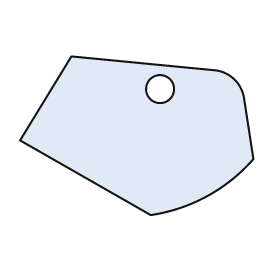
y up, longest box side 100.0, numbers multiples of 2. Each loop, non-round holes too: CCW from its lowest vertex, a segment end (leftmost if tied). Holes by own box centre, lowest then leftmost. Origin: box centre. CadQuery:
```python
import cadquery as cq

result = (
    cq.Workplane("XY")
    .moveTo(6.0, -34.0)
    .threePointArc((30.0, -26.0), (50.0, -10.0))
    .lineTo(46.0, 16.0)
    .threePointArc((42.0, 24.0), (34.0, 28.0))
    .lineTo(-28.0, 34.0)
    .lineTo(-50.0, -2.0)
    .close()
    .moveTo(10.0, 20.0)
    .circle(6.0)
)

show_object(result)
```